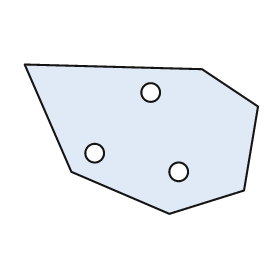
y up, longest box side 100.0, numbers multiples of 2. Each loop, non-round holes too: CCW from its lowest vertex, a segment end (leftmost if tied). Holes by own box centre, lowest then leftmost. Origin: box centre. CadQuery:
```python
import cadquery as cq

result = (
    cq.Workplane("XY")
    .moveTo(12.0, -32.0)
    .lineTo(44.0, -22.0)
    .lineTo(50.0, 14.0)
    .lineTo(26.0, 30.0)
    .lineTo(-50.0, 32.0)
    .lineTo(-30.0, -14.0)
    .close()
    .moveTo(16.0, -14.0)
    .circle(4.0)
    .moveTo(-20.0, -6.0)
    .circle(4.0)
    .moveTo(4.0, 20.0)
    .circle(4.0)
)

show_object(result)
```